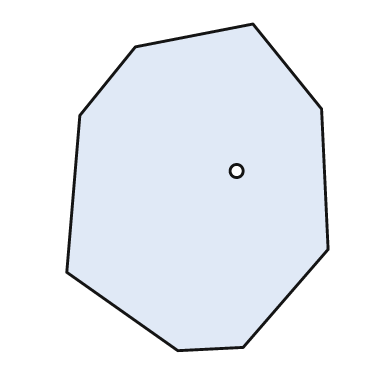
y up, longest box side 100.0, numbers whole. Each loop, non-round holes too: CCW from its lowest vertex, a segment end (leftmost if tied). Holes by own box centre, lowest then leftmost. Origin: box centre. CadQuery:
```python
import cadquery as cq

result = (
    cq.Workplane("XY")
    .moveTo(-6.0, -50.0)
    .lineTo(14.0, -49.0)
    .lineTo(40.0, -19.0)
    .lineTo(38.0, 24.0)
    .lineTo(17.0, 50.0)
    .lineTo(-19.0, 43.0)
    .lineTo(-36.0, 22.0)
    .lineTo(-40.0, -26.0)
    .close()
    .moveTo(12.0, 5.0)
    .circle(2.0)
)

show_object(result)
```